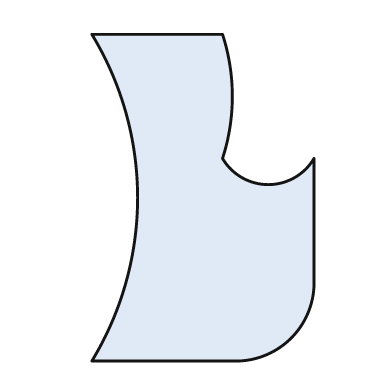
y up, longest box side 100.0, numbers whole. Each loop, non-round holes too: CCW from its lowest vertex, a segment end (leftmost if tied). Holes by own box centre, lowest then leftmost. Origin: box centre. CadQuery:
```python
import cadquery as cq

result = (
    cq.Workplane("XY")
    .moveTo(-34.0, -50.0)
    .lineTo(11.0, -50.0)
    .threePointArc((27.0, -43.0), (34.0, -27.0))
    .lineTo(34.0, 12.0)
    .threePointArc((20.0, 4.0), (6.0, 12.0))
    .threePointArc((9.0, 31.0), (6.0, 50.0))
    .lineTo(-34.0, 50.0)
    .threePointArc((-20.0, 0.0), (-34.0, -50.0))
    .close()
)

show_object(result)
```